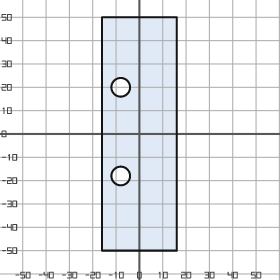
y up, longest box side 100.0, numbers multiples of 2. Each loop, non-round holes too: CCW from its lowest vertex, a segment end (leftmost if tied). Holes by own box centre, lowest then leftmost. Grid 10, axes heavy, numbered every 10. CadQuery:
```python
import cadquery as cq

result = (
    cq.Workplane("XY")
    .moveTo(-16.0, -50.0)
    .lineTo(16.0, -50.0)
    .lineTo(16.0, 50.0)
    .lineTo(-16.0, 50.0)
    .close()
    .moveTo(-8.0, -18.0)
    .circle(4.0)
    .moveTo(-8.0, 20.0)
    .circle(4.0)
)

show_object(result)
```